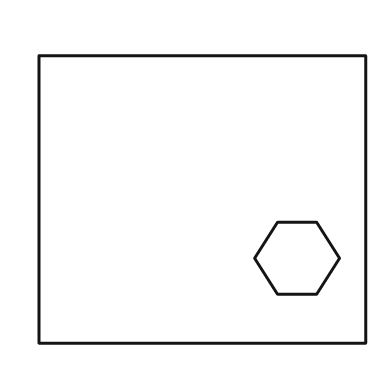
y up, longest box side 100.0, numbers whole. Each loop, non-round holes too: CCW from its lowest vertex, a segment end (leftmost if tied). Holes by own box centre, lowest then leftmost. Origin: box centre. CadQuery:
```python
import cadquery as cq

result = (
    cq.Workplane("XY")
    .moveTo(-50.0, -44.0)
    .lineTo(50.0, -44.0)
    .lineTo(50.0, 44.0)
    .lineTo(-50.0, 44.0)
    .close()
    .moveTo(23.0, -29.0)
    .lineTo(35.0, -29.0)
    .lineTo(42.0, -18.0)
    .lineTo(35.0, -7.0)
    .lineTo(23.0, -7.0)
    .lineTo(16.0, -18.0)
    .close()
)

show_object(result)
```